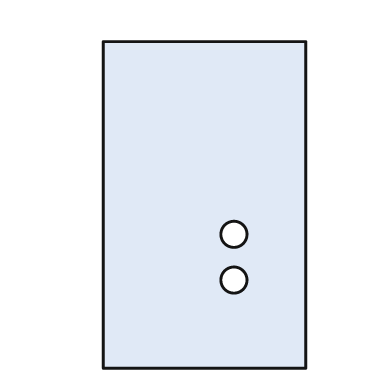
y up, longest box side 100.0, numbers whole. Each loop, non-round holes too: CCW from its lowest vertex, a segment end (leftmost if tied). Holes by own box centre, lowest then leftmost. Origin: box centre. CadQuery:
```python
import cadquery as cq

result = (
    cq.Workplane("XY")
    .moveTo(-31.0, -50.0)
    .lineTo(31.0, -50.0)
    .lineTo(31.0, 50.0)
    .lineTo(-31.0, 50.0)
    .close()
    .moveTo(9.0, -23.0)
    .circle(4.0)
    .moveTo(9.0, -9.0)
    .circle(4.0)
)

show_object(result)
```